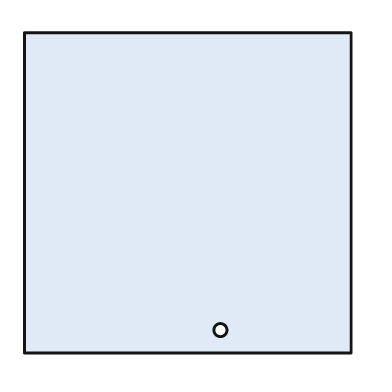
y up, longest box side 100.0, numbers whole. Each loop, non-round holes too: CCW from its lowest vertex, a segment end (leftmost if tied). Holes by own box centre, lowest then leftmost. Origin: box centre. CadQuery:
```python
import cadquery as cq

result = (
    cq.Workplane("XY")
    .moveTo(-50.0, -49.0)
    .lineTo(50.0, -49.0)
    .lineTo(50.0, 49.0)
    .lineTo(-50.0, 49.0)
    .close()
    .moveTo(10.0, -42.0)
    .circle(2.0)
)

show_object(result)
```